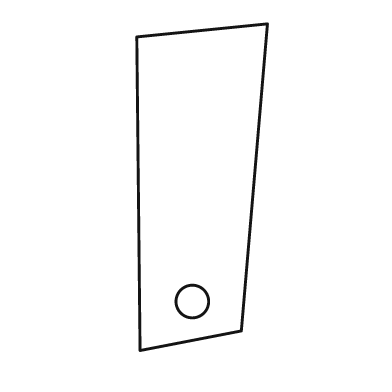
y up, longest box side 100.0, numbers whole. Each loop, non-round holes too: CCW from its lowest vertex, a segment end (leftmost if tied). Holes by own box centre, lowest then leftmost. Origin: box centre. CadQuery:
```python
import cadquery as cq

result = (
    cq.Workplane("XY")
    .moveTo(-19.0, -50.0)
    .lineTo(12.0, -44.0)
    .lineTo(20.0, 50.0)
    .lineTo(-20.0, 46.0)
    .close()
    .moveTo(-3.0, -35.0)
    .circle(5.0)
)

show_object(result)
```